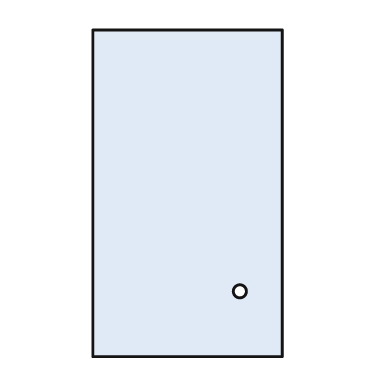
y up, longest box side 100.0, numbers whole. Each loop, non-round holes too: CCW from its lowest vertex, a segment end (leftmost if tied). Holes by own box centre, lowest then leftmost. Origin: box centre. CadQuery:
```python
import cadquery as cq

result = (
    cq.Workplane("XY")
    .moveTo(-29.0, -50.0)
    .lineTo(29.0, -50.0)
    .lineTo(29.0, 50.0)
    .lineTo(-29.0, 50.0)
    .close()
    .moveTo(16.0, -30.0)
    .circle(2.0)
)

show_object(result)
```